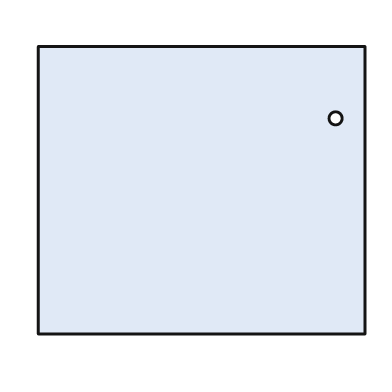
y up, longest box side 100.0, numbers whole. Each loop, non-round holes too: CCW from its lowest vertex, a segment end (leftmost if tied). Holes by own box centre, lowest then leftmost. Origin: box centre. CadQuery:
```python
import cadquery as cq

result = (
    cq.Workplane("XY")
    .moveTo(-50.0, -44.0)
    .lineTo(50.0, -44.0)
    .lineTo(50.0, 44.0)
    .lineTo(-50.0, 44.0)
    .close()
    .moveTo(41.0, 22.0)
    .circle(2.0)
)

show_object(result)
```